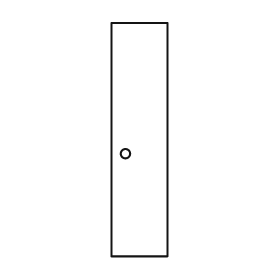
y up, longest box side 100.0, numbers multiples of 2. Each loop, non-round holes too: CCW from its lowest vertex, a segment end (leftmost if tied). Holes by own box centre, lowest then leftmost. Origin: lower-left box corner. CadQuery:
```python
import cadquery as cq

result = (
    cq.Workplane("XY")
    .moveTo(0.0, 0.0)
    .lineTo(24.0, 0.0)
    .lineTo(24.0, 100.0)
    .lineTo(0.0, 100.0)
    .close()
    .moveTo(6.0, 44.0)
    .circle(2.0)
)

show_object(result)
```